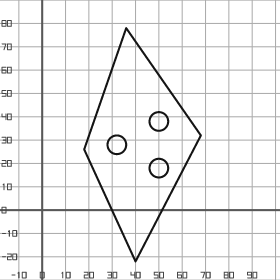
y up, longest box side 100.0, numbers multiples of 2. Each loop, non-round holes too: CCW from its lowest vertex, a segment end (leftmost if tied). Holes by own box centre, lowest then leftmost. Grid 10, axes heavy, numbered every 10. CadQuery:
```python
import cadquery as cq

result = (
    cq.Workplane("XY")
    .moveTo(40.0, -22.0)
    .lineTo(68.0, 32.0)
    .lineTo(36.0, 78.0)
    .lineTo(18.0, 26.0)
    .close()
    .moveTo(50.0, 18.0)
    .circle(4.0)
    .moveTo(32.0, 28.0)
    .circle(4.0)
    .moveTo(50.0, 38.0)
    .circle(4.0)
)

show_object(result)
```